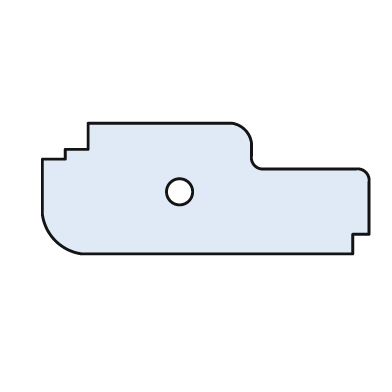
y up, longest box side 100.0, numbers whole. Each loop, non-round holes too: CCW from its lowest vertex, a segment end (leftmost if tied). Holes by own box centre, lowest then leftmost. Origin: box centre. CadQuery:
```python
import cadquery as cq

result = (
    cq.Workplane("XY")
    .moveTo(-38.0, -20.0)
    .lineTo(45.0, -20.0)
    .lineTo(45.0, -14.0)
    .lineTo(50.0, -14.0)
    .lineTo(50.0, 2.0)
    .threePointArc((49.0, 5.0), (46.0, 6.0))
    .lineTo(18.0, 6.0)
    .threePointArc((15.0, 7.0), (14.0, 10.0))
    .lineTo(14.0, 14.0)
    .threePointArc((12.0, 18.0), (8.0, 20.0))
    .lineTo(-36.0, 20.0)
    .lineTo(-36.0, 12.0)
    .lineTo(-43.0, 12.0)
    .lineTo(-43.0, 9.0)
    .lineTo(-50.0, 9.0)
    .lineTo(-50.0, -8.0)
    .threePointArc((-46.0, -16.0), (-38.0, -20.0))
    .close()
    .moveTo(-8.0, -1.0)
    .circle(4.0)
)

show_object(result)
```